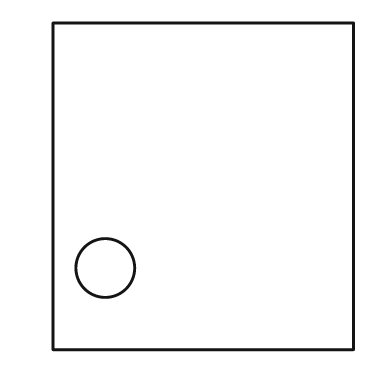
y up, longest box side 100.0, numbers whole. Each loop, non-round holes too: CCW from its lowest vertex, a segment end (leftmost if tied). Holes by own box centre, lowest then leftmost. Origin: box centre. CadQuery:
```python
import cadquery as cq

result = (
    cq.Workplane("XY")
    .moveTo(-46.0, -50.0)
    .lineTo(46.0, -50.0)
    .lineTo(46.0, 50.0)
    .lineTo(-46.0, 50.0)
    .close()
    .moveTo(-30.0, -25.0)
    .circle(9.0)
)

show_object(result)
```